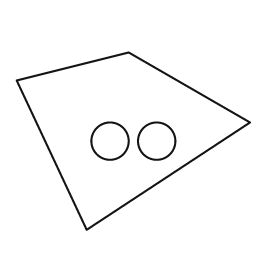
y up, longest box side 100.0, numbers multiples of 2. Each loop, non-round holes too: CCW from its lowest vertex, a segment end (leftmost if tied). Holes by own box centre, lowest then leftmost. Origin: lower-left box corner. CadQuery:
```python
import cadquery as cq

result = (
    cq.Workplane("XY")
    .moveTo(30.0, 0.0)
    .lineTo(100.0, 46.0)
    .lineTo(48.0, 76.0)
    .lineTo(0.0, 64.0)
    .close()
    .moveTo(40.0, 38.0)
    .circle(8.0)
    .moveTo(60.0, 38.0)
    .circle(8.0)
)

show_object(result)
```